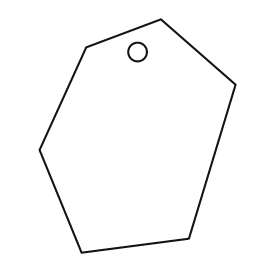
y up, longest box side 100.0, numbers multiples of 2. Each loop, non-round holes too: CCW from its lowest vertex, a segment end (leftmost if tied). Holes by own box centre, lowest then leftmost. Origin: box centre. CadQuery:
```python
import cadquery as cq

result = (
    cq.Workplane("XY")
    .moveTo(-24.0, -50.0)
    .lineTo(22.0, -44.0)
    .lineTo(42.0, 22.0)
    .lineTo(10.0, 50.0)
    .lineTo(-22.0, 38.0)
    .lineTo(-42.0, -6.0)
    .close()
    .moveTo(0.0, 36.0)
    .circle(4.0)
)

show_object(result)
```